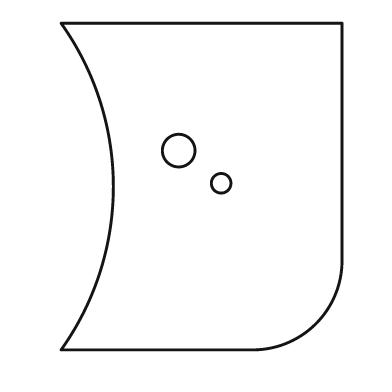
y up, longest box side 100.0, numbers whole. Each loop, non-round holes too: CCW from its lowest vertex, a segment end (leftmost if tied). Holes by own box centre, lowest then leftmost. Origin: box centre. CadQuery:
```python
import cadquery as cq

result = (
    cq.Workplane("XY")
    .moveTo(-43.0, -50.0)
    .lineTo(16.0, -50.0)
    .threePointArc((35.0, -42.0), (43.0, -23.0))
    .lineTo(43.0, 50.0)
    .lineTo(-43.0, 50.0)
    .threePointArc((-27.0, 0.0), (-43.0, -50.0))
    .close()
    .moveTo(6.0, 1.0)
    .circle(3.0)
    .moveTo(-7.0, 11.0)
    .circle(5.0)
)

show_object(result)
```